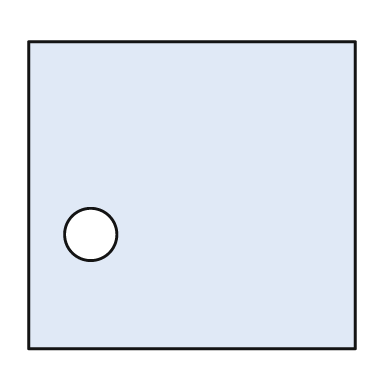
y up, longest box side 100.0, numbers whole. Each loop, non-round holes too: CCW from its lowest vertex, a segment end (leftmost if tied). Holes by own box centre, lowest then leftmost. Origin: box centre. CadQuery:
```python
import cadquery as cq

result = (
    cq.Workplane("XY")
    .moveTo(-50.0, -47.0)
    .lineTo(50.0, -47.0)
    .lineTo(50.0, 47.0)
    .lineTo(-50.0, 47.0)
    .close()
    .moveTo(-31.0, -12.0)
    .circle(8.0)
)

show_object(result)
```